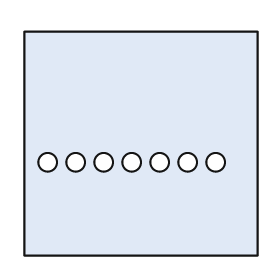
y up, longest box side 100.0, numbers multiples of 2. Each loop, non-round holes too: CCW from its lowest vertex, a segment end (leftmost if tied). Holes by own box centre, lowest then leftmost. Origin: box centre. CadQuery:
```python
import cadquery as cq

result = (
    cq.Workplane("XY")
    .moveTo(-50.0, -48.0)
    .lineTo(50.0, -48.0)
    .lineTo(50.0, 48.0)
    .lineTo(-50.0, 48.0)
    .close()
    .moveTo(-40.0, -8.0)
    .circle(4.0)
    .moveTo(-28.0, -8.0)
    .circle(4.0)
    .moveTo(-16.0, -8.0)
    .circle(4.0)
    .moveTo(-4.0, -8.0)
    .circle(4.0)
    .moveTo(8.0, -8.0)
    .circle(4.0)
    .moveTo(20.0, -8.0)
    .circle(4.0)
    .moveTo(32.0, -8.0)
    .circle(4.0)
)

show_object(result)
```